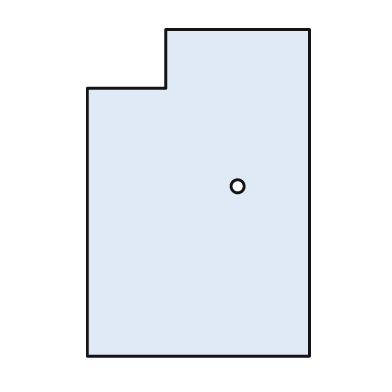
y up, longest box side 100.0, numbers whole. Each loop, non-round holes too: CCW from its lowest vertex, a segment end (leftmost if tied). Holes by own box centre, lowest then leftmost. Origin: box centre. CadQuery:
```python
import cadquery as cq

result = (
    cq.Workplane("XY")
    .moveTo(-34.0, -50.0)
    .lineTo(34.0, -50.0)
    .lineTo(34.0, 50.0)
    .lineTo(-10.0, 50.0)
    .lineTo(-10.0, 32.0)
    .lineTo(-34.0, 32.0)
    .close()
    .moveTo(12.0, 2.0)
    .circle(2.0)
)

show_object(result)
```